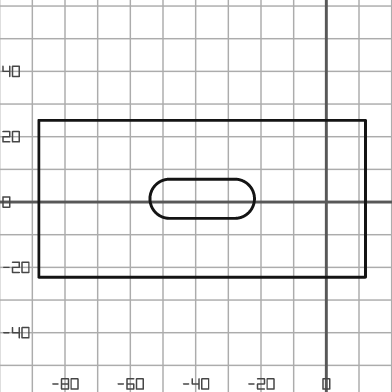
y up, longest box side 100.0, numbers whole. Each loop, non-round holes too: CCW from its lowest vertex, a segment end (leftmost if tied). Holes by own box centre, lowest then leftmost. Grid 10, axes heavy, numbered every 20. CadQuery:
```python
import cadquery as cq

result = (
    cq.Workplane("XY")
    .moveTo(-88.0, -23.0)
    .lineTo(12.0, -23.0)
    .lineTo(12.0, 25.0)
    .lineTo(-88.0, 25.0)
    .close()
    .moveTo(-48.0, -5.0)
    .lineTo(-28.0, -5.0)
    .threePointArc((-22.0, 1.0), (-28.0, 7.0))
    .lineTo(-48.0, 7.0)
    .threePointArc((-54.0, 1.0), (-48.0, -5.0))
    .close()
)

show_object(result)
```